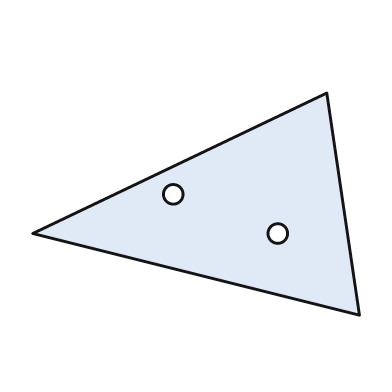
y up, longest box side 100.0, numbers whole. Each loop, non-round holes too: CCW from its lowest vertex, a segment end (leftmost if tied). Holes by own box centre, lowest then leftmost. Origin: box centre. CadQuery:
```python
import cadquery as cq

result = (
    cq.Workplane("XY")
    .moveTo(50.0, -34.0)
    .lineTo(40.0, 34.0)
    .lineTo(-50.0, -9.0)
    .close()
    .moveTo(25.0, -9.0)
    .circle(3.0)
    .moveTo(-7.0, 3.0)
    .circle(3.0)
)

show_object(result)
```